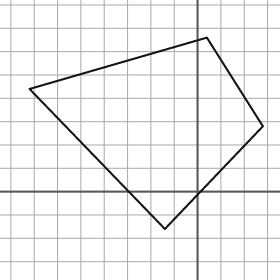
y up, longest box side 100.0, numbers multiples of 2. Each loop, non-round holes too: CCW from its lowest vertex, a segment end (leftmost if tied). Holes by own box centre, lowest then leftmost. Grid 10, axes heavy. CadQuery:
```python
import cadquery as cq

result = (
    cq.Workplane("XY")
    .moveTo(-14.0, -16.0)
    .lineTo(28.0, 28.0)
    .lineTo(4.0, 66.0)
    .lineTo(-72.0, 44.0)
    .close()
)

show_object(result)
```